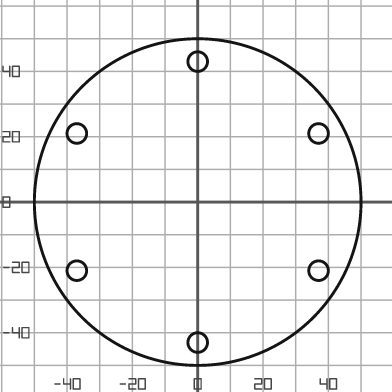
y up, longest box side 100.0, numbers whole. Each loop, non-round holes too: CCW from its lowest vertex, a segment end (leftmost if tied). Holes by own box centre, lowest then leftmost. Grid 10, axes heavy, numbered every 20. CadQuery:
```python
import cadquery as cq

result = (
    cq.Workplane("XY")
    .moveTo(0.0, 0.0)
    .circle(50.0)
    .moveTo(0.0, -43.0)
    .circle(3.0)
    .moveTo(-37.0, -21.0)
    .circle(3.0)
    .moveTo(37.0, -21.0)
    .circle(3.0)
    .moveTo(-37.0, 21.0)
    .circle(3.0)
    .moveTo(37.0, 21.0)
    .circle(3.0)
    .moveTo(0.0, 43.0)
    .circle(3.0)
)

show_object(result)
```